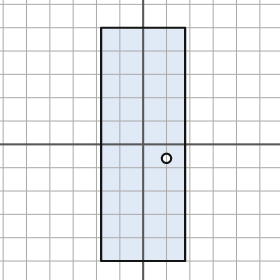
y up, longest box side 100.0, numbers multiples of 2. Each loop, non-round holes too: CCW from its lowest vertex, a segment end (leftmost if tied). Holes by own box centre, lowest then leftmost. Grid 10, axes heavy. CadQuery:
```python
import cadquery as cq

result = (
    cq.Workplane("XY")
    .moveTo(-18.0, -50.0)
    .lineTo(18.0, -50.0)
    .lineTo(18.0, 50.0)
    .lineTo(-18.0, 50.0)
    .close()
    .moveTo(10.0, -6.0)
    .circle(2.0)
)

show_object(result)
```